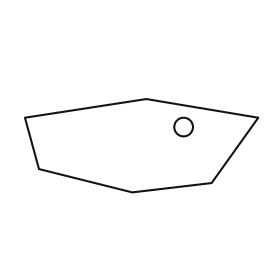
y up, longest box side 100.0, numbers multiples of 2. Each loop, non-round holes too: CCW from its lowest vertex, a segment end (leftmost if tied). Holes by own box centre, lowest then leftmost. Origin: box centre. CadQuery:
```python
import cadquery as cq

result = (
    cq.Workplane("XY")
    .moveTo(-4.0, -20.0)
    .lineTo(30.0, -16.0)
    .lineTo(50.0, 12.0)
    .lineTo(2.0, 20.0)
    .lineTo(-50.0, 12.0)
    .lineTo(-44.0, -10.0)
    .close()
    .moveTo(18.0, 8.0)
    .circle(4.0)
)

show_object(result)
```